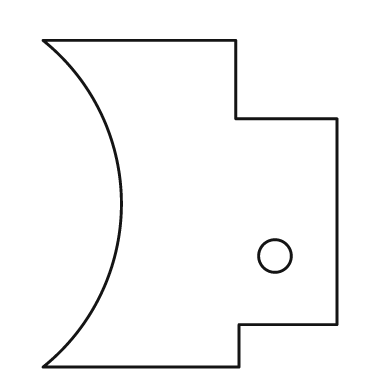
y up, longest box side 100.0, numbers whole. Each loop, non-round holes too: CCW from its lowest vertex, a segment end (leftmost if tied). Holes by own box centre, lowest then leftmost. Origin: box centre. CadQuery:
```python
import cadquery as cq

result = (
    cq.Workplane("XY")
    .moveTo(-45.0, -50.0)
    .lineTo(15.0, -50.0)
    .lineTo(15.0, -37.0)
    .lineTo(45.0, -37.0)
    .lineTo(45.0, 26.0)
    .lineTo(14.0, 26.0)
    .lineTo(14.0, 50.0)
    .lineTo(-45.0, 50.0)
    .threePointArc((-21.0, 0.0), (-45.0, -50.0))
    .close()
    .moveTo(26.0, -16.0)
    .circle(5.0)
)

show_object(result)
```